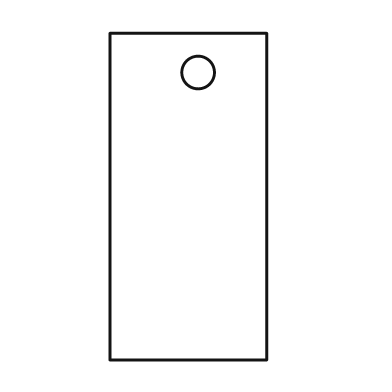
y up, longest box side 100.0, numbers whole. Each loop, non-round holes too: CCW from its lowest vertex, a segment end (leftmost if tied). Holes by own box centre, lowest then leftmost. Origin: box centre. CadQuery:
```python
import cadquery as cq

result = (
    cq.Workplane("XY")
    .moveTo(-24.0, -50.0)
    .lineTo(24.0, -50.0)
    .lineTo(24.0, 50.0)
    .lineTo(-24.0, 50.0)
    .close()
    .moveTo(3.0, 38.0)
    .circle(5.0)
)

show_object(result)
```